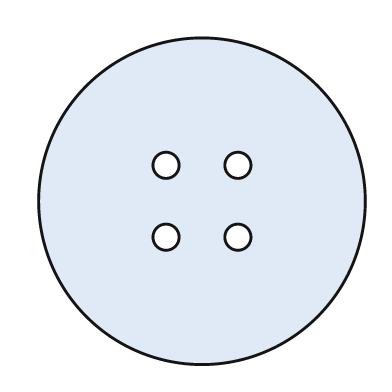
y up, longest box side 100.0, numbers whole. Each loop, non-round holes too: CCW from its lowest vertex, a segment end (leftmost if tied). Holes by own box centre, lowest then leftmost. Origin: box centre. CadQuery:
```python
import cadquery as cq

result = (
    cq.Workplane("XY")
    .moveTo(0.0, 0.0)
    .circle(50.0)
    .moveTo(-11.0, -11.0)
    .circle(4.0)
    .moveTo(11.0, -11.0)
    .circle(4.0)
    .moveTo(-11.0, 11.0)
    .circle(4.0)
    .moveTo(11.0, 11.0)
    .circle(4.0)
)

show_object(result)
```